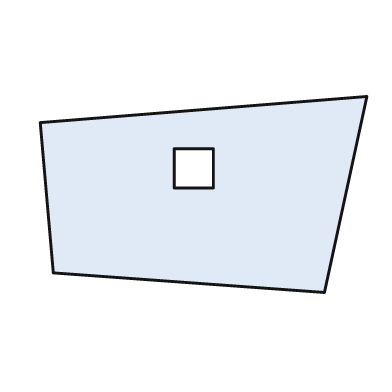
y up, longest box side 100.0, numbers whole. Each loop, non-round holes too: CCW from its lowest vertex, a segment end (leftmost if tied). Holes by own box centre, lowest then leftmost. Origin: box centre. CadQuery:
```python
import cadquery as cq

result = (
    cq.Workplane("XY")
    .moveTo(37.0, -30.0)
    .lineTo(50.0, 30.0)
    .lineTo(-50.0, 22.0)
    .lineTo(-46.0, -24.0)
    .close()
    .moveTo(-9.0, 2.0)
    .lineTo(3.0, 2.0)
    .lineTo(3.0, 14.0)
    .lineTo(-9.0, 14.0)
    .close()
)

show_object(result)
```